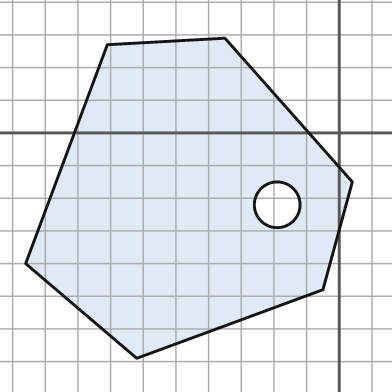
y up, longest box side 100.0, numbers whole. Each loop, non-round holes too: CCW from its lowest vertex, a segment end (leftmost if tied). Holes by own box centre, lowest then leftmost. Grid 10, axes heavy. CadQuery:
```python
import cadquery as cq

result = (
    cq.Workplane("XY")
    .moveTo(-62.0, -69.0)
    .lineTo(-5.0, -48.0)
    .lineTo(4.0, -15.0)
    .lineTo(-35.0, 29.0)
    .lineTo(-71.0, 27.0)
    .lineTo(-96.0, -40.0)
    .close()
    .moveTo(-19.0, -22.0)
    .circle(7.0)
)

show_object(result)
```